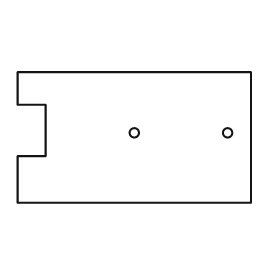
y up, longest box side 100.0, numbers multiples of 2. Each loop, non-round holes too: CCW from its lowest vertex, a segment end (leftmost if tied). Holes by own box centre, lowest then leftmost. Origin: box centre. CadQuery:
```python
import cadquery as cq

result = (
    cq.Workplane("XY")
    .moveTo(-50.0, -28.0)
    .lineTo(50.0, -28.0)
    .lineTo(50.0, 28.0)
    .lineTo(-50.0, 28.0)
    .lineTo(-50.0, 14.0)
    .lineTo(-38.0, 14.0)
    .lineTo(-38.0, -8.0)
    .lineTo(-50.0, -8.0)
    .close()
    .moveTo(0.0, 2.0)
    .circle(2.0)
    .moveTo(40.0, 2.0)
    .circle(2.0)
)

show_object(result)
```